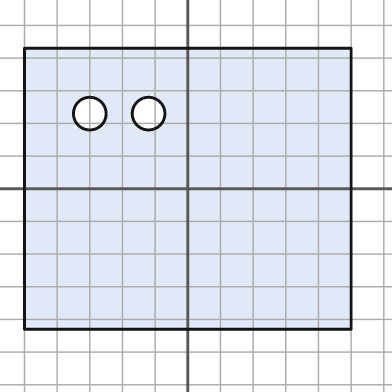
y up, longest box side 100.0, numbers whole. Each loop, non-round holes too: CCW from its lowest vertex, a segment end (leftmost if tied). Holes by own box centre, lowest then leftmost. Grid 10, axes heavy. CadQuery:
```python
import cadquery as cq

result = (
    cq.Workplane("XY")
    .moveTo(-50.0, -43.0)
    .lineTo(50.0, -43.0)
    .lineTo(50.0, 43.0)
    .lineTo(-50.0, 43.0)
    .close()
    .moveTo(-30.0, 23.0)
    .circle(5.0)
    .moveTo(-12.0, 23.0)
    .circle(5.0)
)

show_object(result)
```